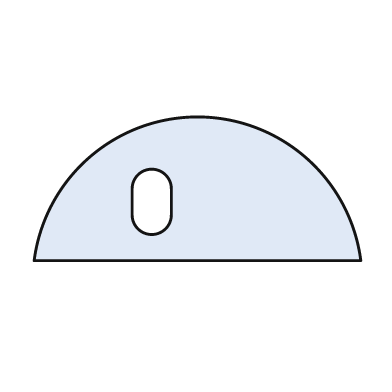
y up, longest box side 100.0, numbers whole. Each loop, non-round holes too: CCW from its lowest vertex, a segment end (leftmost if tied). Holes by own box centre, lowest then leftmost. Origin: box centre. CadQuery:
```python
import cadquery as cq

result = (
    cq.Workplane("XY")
    .moveTo(-50.0, -22.0)
    .lineTo(50.0, -22.0)
    .threePointArc((0.0, 22.0), (-50.0, -22.0))
    .close()
    .moveTo(-20.0, -8.0)
    .threePointArc((-14.0, -14.0), (-8.0, -8.0))
    .lineTo(-8.0, 0.0)
    .threePointArc((-14.0, 6.0), (-20.0, 0.0))
    .close()
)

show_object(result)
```